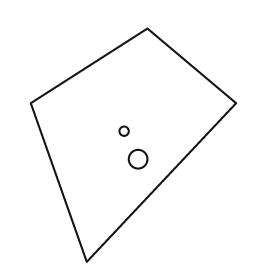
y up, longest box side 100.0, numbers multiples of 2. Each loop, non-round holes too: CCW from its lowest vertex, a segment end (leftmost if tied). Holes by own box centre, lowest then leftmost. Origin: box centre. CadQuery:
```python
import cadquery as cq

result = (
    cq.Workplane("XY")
    .moveTo(-20.0, -50.0)
    .lineTo(44.0, 18.0)
    .lineTo(6.0, 50.0)
    .lineTo(-44.0, 18.0)
    .close()
    .moveTo(2.0, -6.0)
    .circle(4.0)
    .moveTo(-4.0, 6.0)
    .circle(2.0)
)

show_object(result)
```